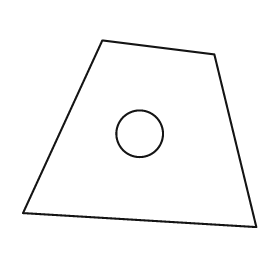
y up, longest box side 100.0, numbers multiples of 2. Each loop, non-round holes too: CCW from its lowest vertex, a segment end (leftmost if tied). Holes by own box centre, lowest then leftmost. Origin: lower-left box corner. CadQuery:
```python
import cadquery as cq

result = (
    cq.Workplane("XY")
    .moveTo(100.0, 0.0)
    .lineTo(82.0, 74.0)
    .lineTo(34.0, 80.0)
    .lineTo(0.0, 6.0)
    .close()
    .moveTo(50.0, 40.0)
    .circle(10.0)
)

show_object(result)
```